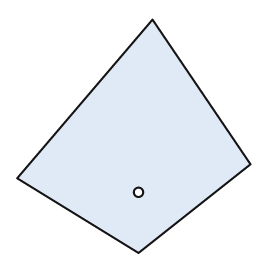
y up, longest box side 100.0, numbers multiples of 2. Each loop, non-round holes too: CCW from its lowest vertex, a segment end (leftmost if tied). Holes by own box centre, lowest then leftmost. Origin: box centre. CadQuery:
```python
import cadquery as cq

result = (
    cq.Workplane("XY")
    .moveTo(2.0, -50.0)
    .lineTo(50.0, -12.0)
    .lineTo(8.0, 50.0)
    .lineTo(-50.0, -18.0)
    .close()
    .moveTo(2.0, -24.0)
    .circle(2.0)
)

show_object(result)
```